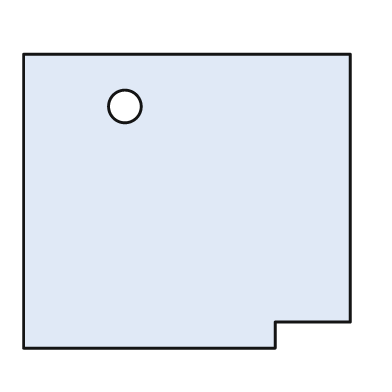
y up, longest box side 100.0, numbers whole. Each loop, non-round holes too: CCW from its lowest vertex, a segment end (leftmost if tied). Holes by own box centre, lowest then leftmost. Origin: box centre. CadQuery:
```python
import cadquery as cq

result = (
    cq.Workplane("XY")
    .moveTo(-50.0, -45.0)
    .lineTo(27.0, -45.0)
    .lineTo(27.0, -37.0)
    .lineTo(50.0, -37.0)
    .lineTo(50.0, 45.0)
    .lineTo(-50.0, 45.0)
    .close()
    .moveTo(-19.0, 29.0)
    .circle(5.0)
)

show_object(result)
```